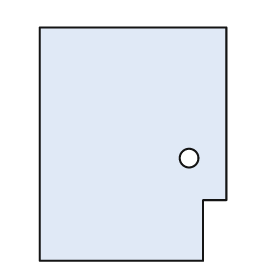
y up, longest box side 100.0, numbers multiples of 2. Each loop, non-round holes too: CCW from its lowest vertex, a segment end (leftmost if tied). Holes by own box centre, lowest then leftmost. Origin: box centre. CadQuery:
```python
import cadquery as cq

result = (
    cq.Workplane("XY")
    .moveTo(-40.0, -50.0)
    .lineTo(30.0, -50.0)
    .lineTo(30.0, -24.0)
    .lineTo(40.0, -24.0)
    .lineTo(40.0, 50.0)
    .lineTo(-40.0, 50.0)
    .close()
    .moveTo(24.0, -6.0)
    .circle(4.0)
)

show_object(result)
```